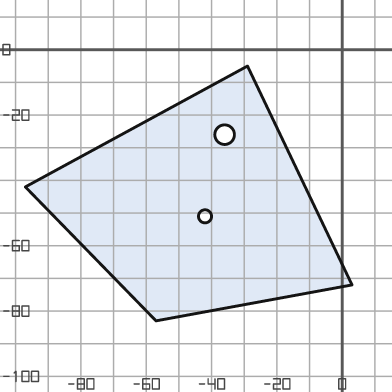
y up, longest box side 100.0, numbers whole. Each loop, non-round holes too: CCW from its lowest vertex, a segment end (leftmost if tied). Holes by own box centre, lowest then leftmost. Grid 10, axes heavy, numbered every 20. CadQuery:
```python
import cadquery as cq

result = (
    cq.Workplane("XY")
    .moveTo(-57.0, -83.0)
    .lineTo(3.0, -72.0)
    .lineTo(-29.0, -5.0)
    .lineTo(-97.0, -42.0)
    .close()
    .moveTo(-42.0, -51.0)
    .circle(2.0)
    .moveTo(-36.0, -26.0)
    .circle(3.0)
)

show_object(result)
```